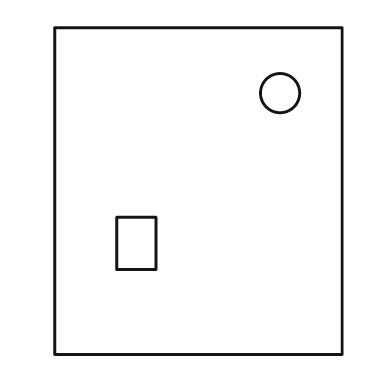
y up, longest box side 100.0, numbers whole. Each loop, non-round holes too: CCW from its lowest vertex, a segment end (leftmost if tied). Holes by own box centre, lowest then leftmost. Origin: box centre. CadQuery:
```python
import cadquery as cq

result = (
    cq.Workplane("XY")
    .moveTo(-44.0, -50.0)
    .lineTo(44.0, -50.0)
    .lineTo(44.0, 50.0)
    .lineTo(-44.0, 50.0)
    .close()
    .moveTo(-25.0, -24.0)
    .lineTo(-13.0, -24.0)
    .lineTo(-13.0, -8.0)
    .lineTo(-25.0, -8.0)
    .close()
    .moveTo(25.0, 30.0)
    .circle(6.0)
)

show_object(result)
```